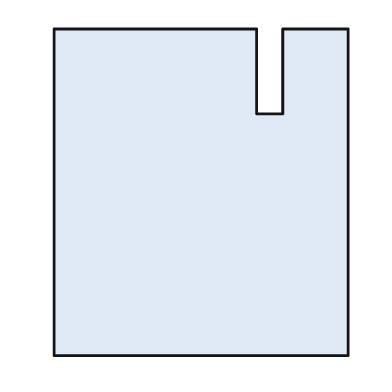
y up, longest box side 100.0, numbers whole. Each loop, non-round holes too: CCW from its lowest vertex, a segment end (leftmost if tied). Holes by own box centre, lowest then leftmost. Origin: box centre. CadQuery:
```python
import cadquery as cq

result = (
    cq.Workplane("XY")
    .moveTo(-45.0, -50.0)
    .lineTo(45.0, -50.0)
    .lineTo(45.0, 50.0)
    .lineTo(25.0, 50.0)
    .lineTo(25.0, 24.0)
    .lineTo(17.0, 24.0)
    .lineTo(17.0, 50.0)
    .lineTo(-45.0, 50.0)
    .close()
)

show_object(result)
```